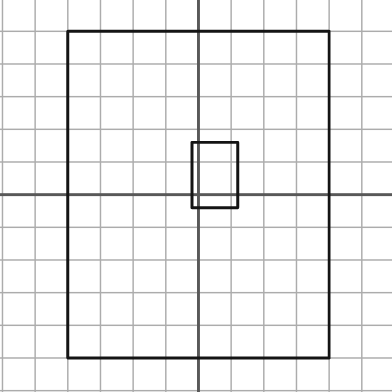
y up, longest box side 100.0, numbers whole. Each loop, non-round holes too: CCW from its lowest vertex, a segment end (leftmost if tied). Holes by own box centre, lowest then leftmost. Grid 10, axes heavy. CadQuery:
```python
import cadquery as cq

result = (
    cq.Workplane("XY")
    .moveTo(-40.0, -50.0)
    .lineTo(40.0, -50.0)
    .lineTo(40.0, 50.0)
    .lineTo(-40.0, 50.0)
    .close()
    .moveTo(-2.0, -4.0)
    .lineTo(12.0, -4.0)
    .lineTo(12.0, 16.0)
    .lineTo(-2.0, 16.0)
    .close()
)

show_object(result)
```